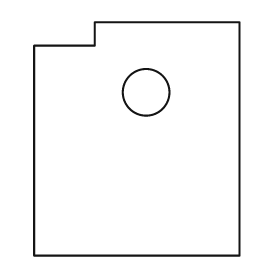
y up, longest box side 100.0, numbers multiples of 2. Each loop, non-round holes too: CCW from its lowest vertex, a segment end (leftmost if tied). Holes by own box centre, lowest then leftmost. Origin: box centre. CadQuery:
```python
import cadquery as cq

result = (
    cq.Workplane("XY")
    .moveTo(-44.0, -50.0)
    .lineTo(44.0, -50.0)
    .lineTo(44.0, 50.0)
    .lineTo(-18.0, 50.0)
    .lineTo(-18.0, 40.0)
    .lineTo(-44.0, 40.0)
    .close()
    .moveTo(4.0, 20.0)
    .circle(10.0)
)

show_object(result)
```